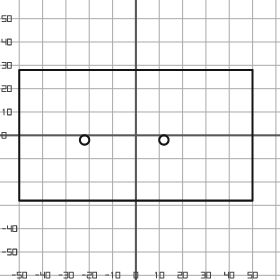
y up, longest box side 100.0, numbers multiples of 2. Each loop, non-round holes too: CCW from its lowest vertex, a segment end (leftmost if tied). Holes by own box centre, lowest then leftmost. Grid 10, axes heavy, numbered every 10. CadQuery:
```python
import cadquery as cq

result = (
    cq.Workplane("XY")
    .moveTo(-50.0, -28.0)
    .lineTo(50.0, -28.0)
    .lineTo(50.0, 28.0)
    .lineTo(-50.0, 28.0)
    .close()
    .moveTo(-22.0, -2.0)
    .circle(2.0)
    .moveTo(12.0, -2.0)
    .circle(2.0)
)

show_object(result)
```